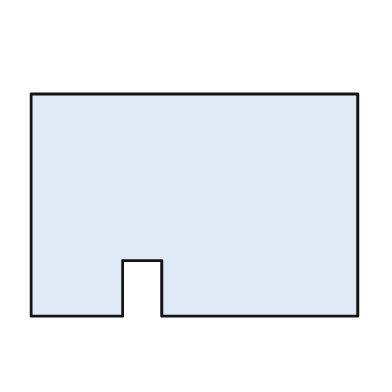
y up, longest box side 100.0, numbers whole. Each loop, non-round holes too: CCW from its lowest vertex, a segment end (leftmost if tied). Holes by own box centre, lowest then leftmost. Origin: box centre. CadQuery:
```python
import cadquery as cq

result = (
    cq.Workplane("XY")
    .moveTo(-50.0, -34.0)
    .lineTo(-22.0, -34.0)
    .lineTo(-22.0, -17.0)
    .lineTo(-10.0, -17.0)
    .lineTo(-10.0, -34.0)
    .lineTo(50.0, -34.0)
    .lineTo(50.0, 34.0)
    .lineTo(-50.0, 34.0)
    .close()
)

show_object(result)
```